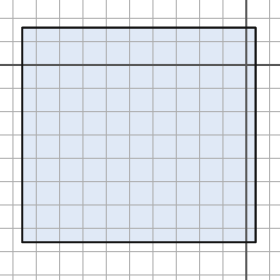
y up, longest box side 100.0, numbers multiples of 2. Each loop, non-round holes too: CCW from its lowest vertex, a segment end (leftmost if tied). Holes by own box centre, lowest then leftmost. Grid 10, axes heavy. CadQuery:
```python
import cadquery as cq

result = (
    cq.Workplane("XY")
    .moveTo(-96.0, -76.0)
    .lineTo(4.0, -76.0)
    .lineTo(4.0, 16.0)
    .lineTo(-96.0, 16.0)
    .close()
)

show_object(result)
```